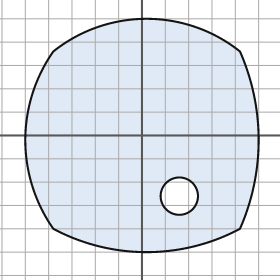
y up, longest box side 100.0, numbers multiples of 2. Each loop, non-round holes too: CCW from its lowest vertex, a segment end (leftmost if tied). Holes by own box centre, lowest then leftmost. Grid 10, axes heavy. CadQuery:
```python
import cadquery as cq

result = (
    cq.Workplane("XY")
    .moveTo(-38.0, -40.0)
    .threePointArc((2.0, -50.0), (42.0, -40.0))
    .threePointArc((50.0, -2.0), (42.0, 36.0))
    .threePointArc((2.0, 50.0), (-38.0, 36.0))
    .threePointArc((-50.0, -2.0), (-38.0, -40.0))
    .close()
    .moveTo(16.0, -26.0)
    .circle(8.0)
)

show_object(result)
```